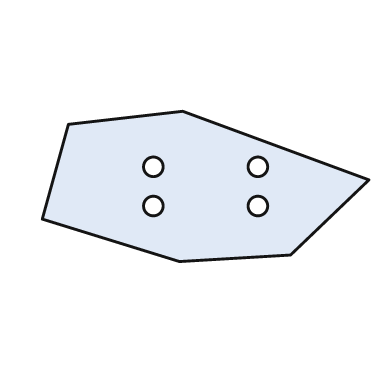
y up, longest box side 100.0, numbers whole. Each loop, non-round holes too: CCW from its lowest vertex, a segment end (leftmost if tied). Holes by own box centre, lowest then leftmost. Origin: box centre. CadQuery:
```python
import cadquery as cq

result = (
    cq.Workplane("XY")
    .moveTo(-8.0, -23.0)
    .lineTo(26.0, -21.0)
    .lineTo(50.0, 2.0)
    .lineTo(-7.0, 23.0)
    .lineTo(-42.0, 19.0)
    .lineTo(-50.0, -10.0)
    .close()
    .moveTo(-16.0, -6.0)
    .circle(3.0)
    .moveTo(16.0, -6.0)
    .circle(3.0)
    .moveTo(-16.0, 6.0)
    .circle(3.0)
    .moveTo(16.0, 6.0)
    .circle(3.0)
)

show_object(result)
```